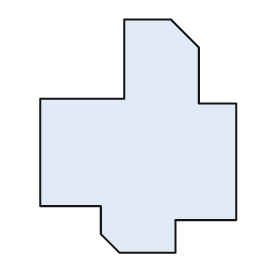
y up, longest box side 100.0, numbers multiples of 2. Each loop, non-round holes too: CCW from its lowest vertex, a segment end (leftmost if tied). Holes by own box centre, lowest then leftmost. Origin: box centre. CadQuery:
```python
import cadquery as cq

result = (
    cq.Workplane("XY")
    .moveTo(-8.0, -50.0)
    .lineTo(16.0, -50.0)
    .lineTo(16.0, -36.0)
    .lineTo(42.0, -36.0)
    .lineTo(42.0, 14.0)
    .lineTo(26.0, 14.0)
    .lineTo(26.0, 38.0)
    .lineTo(14.0, 50.0)
    .lineTo(-6.0, 50.0)
    .lineTo(-6.0, 16.0)
    .lineTo(-42.0, 16.0)
    .lineTo(-42.0, -30.0)
    .lineTo(-16.0, -30.0)
    .lineTo(-16.0, -42.0)
    .close()
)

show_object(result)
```